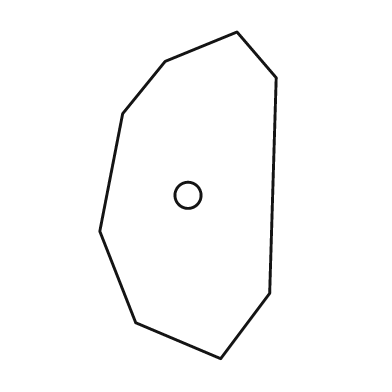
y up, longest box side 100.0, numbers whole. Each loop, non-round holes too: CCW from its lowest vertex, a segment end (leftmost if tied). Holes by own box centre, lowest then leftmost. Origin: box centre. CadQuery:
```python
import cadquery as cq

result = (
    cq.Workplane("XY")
    .moveTo(10.0, -50.0)
    .lineTo(25.0, -30.0)
    .lineTo(27.0, 36.0)
    .lineTo(15.0, 50.0)
    .lineTo(-7.0, 41.0)
    .lineTo(-20.0, 25.0)
    .lineTo(-27.0, -11.0)
    .lineTo(-16.0, -39.0)
    .close()
    .moveTo(0.0, 0.0)
    .circle(4.0)
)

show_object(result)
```